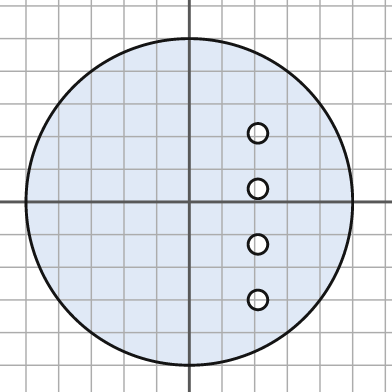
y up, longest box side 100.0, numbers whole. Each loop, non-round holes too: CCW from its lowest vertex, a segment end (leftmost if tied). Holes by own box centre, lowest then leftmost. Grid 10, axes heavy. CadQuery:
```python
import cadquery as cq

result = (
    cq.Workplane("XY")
    .moveTo(0.0, 0.0)
    .circle(50.0)
    .moveTo(21.0, -30.0)
    .circle(3.0)
    .moveTo(21.0, -13.0)
    .circle(3.0)
    .moveTo(21.0, 4.0)
    .circle(3.0)
    .moveTo(21.0, 21.0)
    .circle(3.0)
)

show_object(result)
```